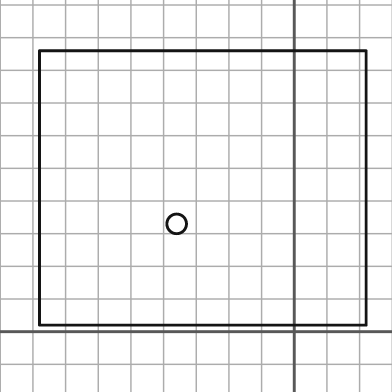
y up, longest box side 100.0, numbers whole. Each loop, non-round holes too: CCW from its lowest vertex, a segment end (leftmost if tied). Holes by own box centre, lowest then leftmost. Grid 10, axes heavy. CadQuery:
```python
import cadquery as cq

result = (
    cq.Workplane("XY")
    .moveTo(-78.0, 2.0)
    .lineTo(22.0, 2.0)
    .lineTo(22.0, 86.0)
    .lineTo(-78.0, 86.0)
    .close()
    .moveTo(-36.0, 33.0)
    .circle(3.0)
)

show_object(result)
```